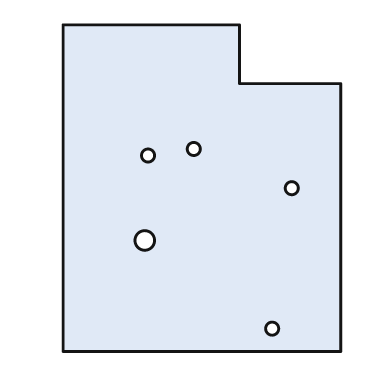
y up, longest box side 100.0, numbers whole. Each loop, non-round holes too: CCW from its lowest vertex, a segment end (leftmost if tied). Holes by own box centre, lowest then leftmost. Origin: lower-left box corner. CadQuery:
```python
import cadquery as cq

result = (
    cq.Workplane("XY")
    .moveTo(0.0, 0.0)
    .lineTo(85.0, 0.0)
    .lineTo(85.0, 82.0)
    .lineTo(54.0, 82.0)
    .lineTo(54.0, 100.0)
    .lineTo(0.0, 100.0)
    .close()
    .moveTo(64.0, 7.0)
    .circle(2.0)
    .moveTo(25.0, 34.0)
    .circle(3.0)
    .moveTo(70.0, 50.0)
    .circle(2.0)
    .moveTo(26.0, 60.0)
    .circle(2.0)
    .moveTo(40.0, 62.0)
    .circle(2.0)
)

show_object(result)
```